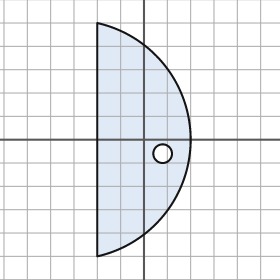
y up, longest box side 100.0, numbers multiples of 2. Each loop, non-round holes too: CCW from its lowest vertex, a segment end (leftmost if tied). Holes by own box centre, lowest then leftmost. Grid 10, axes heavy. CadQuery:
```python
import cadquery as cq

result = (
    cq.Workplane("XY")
    .moveTo(-20.0, -50.0)
    .threePointArc((20.0, 0.0), (-20.0, 50.0))
    .close()
    .moveTo(8.0, -6.0)
    .circle(4.0)
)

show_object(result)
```